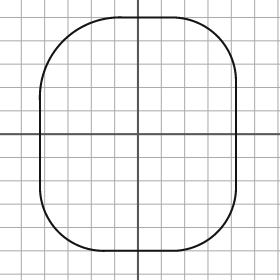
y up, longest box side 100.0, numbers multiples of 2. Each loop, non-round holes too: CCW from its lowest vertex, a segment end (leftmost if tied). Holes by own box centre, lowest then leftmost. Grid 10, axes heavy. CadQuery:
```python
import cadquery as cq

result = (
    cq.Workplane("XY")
    .moveTo(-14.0, -50.0)
    .lineTo(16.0, -50.0)
    .threePointArc((34.0, -42.0), (42.0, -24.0))
    .lineTo(42.0, 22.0)
    .threePointArc((34.0, 42.0), (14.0, 50.0))
    .lineTo(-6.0, 50.0)
    .threePointArc((-32.0, 40.0), (-42.0, 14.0))
    .lineTo(-42.0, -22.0)
    .threePointArc((-34.0, -42.0), (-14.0, -50.0))
    .close()
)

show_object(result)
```